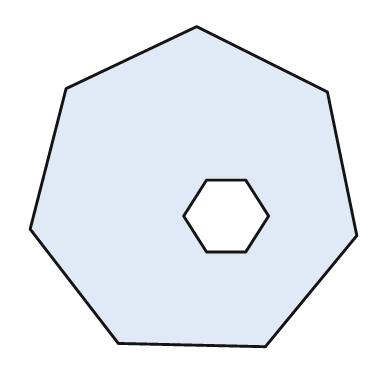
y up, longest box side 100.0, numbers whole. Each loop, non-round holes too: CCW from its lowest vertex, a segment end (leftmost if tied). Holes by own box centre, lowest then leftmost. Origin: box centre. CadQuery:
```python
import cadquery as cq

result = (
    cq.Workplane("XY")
    .moveTo(22.0, -49.0)
    .lineTo(50.0, -15.0)
    .lineTo(41.0, 29.0)
    .lineTo(1.0, 49.0)
    .lineTo(-39.0, 30.0)
    .lineTo(-50.0, -13.0)
    .lineTo(-23.0, -48.0)
    .close()
    .moveTo(4.0, -20.0)
    .lineTo(16.0, -20.0)
    .lineTo(23.0, -9.0)
    .lineTo(16.0, 2.0)
    .lineTo(4.0, 2.0)
    .lineTo(-3.0, -9.0)
    .close()
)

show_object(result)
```